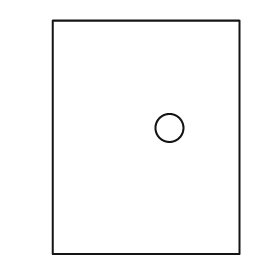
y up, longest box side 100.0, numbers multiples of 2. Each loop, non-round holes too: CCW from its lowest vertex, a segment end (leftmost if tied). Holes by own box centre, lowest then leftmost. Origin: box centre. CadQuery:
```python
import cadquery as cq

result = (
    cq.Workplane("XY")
    .moveTo(-40.0, -50.0)
    .lineTo(40.0, -50.0)
    .lineTo(40.0, 50.0)
    .lineTo(-40.0, 50.0)
    .close()
    .moveTo(10.0, 4.0)
    .circle(6.0)
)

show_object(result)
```